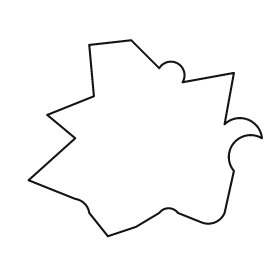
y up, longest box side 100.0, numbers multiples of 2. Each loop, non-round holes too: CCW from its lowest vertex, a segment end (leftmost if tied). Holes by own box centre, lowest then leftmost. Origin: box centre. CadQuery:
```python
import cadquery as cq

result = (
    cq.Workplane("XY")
    .moveTo(-16.0, -42.0)
    .lineTo(-4.0, -38.0)
    .lineTo(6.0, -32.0)
    .threePointArc((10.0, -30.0), (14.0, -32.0))
    .lineTo(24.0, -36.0)
    .threePointArc((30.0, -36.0), (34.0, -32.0))
    .lineTo(38.0, -14.0)
    .threePointArc((38.0, -2.0), (50.0, 0.0))
    .threePointArc((44.0, 8.0), (34.0, 6.0))
    .lineTo(38.0, 28.0)
    .lineTo(16.0, 24.0)
    .threePointArc((14.0, 32.0), (6.0, 30.0))
    .lineTo(-6.0, 42.0)
    .lineTo(-24.0, 40.0)
    .lineTo(-22.0, 18.0)
    .lineTo(-42.0, 10.0)
    .lineTo(-30.0, 0.0)
    .lineTo(-50.0, -18.0)
    .lineTo(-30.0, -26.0)
    .threePointArc((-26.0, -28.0), (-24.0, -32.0))
    .close()
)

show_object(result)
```